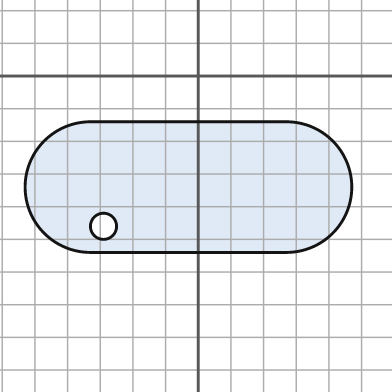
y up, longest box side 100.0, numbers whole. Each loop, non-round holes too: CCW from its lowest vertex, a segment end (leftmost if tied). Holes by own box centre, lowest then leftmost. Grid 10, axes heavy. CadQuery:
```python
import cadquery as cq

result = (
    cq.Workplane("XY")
    .moveTo(-33.0, -54.0)
    .lineTo(27.0, -54.0)
    .threePointArc((47.0, -34.0), (27.0, -14.0))
    .lineTo(-33.0, -14.0)
    .threePointArc((-53.0, -34.0), (-33.0, -54.0))
    .close()
    .moveTo(-29.0, -46.0)
    .circle(4.0)
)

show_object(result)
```